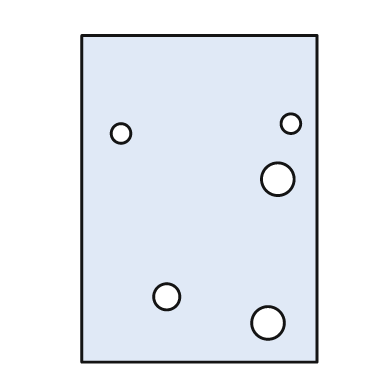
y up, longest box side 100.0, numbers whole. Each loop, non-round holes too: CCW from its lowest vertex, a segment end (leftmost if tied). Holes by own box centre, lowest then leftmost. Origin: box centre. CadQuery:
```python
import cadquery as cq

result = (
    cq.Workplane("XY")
    .moveTo(-36.0, -50.0)
    .lineTo(36.0, -50.0)
    .lineTo(36.0, 50.0)
    .lineTo(-36.0, 50.0)
    .close()
    .moveTo(21.0, -38.0)
    .circle(5.0)
    .moveTo(-10.0, -30.0)
    .circle(4.0)
    .moveTo(24.0, 6.0)
    .circle(5.0)
    .moveTo(-24.0, 20.0)
    .circle(3.0)
    .moveTo(28.0, 23.0)
    .circle(3.0)
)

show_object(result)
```